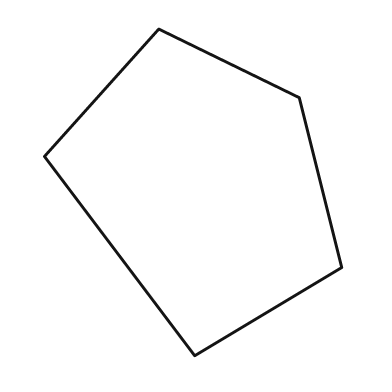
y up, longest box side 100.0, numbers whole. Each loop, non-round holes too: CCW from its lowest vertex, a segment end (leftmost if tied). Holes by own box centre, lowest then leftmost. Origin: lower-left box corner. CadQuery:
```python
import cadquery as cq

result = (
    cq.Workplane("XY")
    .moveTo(46.0, 0.0)
    .lineTo(91.0, 27.0)
    .lineTo(78.0, 79.0)
    .lineTo(35.0, 100.0)
    .lineTo(0.0, 61.0)
    .close()
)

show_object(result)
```